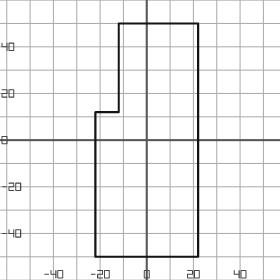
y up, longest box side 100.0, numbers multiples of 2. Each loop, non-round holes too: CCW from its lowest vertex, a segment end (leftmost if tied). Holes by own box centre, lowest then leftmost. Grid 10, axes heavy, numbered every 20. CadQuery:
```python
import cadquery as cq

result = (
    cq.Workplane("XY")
    .moveTo(-22.0, -50.0)
    .lineTo(22.0, -50.0)
    .lineTo(22.0, 50.0)
    .lineTo(-12.0, 50.0)
    .lineTo(-12.0, 12.0)
    .lineTo(-22.0, 12.0)
    .close()
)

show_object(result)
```